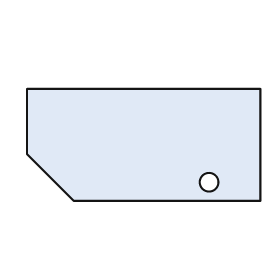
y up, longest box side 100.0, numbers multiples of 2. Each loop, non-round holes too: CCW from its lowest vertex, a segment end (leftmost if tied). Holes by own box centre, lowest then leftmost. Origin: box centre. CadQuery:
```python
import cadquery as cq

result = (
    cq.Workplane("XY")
    .moveTo(-30.0, -24.0)
    .lineTo(50.0, -24.0)
    .lineTo(50.0, 24.0)
    .lineTo(-50.0, 24.0)
    .lineTo(-50.0, -4.0)
    .close()
    .moveTo(28.0, -16.0)
    .circle(4.0)
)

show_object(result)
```